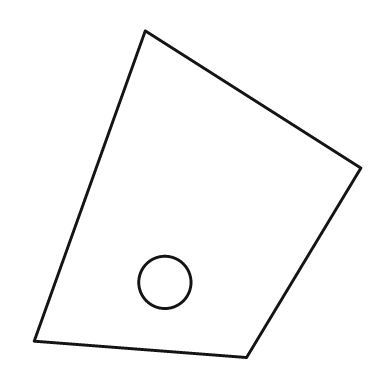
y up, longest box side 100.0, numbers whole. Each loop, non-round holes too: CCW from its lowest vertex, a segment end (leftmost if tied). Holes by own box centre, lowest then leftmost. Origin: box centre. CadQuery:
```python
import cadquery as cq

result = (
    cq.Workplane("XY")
    .moveTo(15.0, -50.0)
    .lineTo(50.0, 8.0)
    .lineTo(-16.0, 50.0)
    .lineTo(-50.0, -45.0)
    .close()
    .moveTo(-10.0, -27.0)
    .circle(8.0)
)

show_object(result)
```